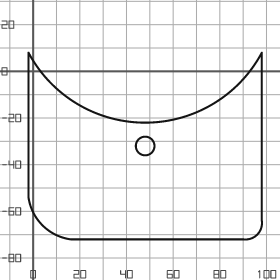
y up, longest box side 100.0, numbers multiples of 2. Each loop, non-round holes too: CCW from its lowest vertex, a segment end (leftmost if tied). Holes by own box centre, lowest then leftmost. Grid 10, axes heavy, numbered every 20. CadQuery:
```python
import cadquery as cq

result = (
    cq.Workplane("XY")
    .moveTo(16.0, -72.0)
    .lineTo(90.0, -72.0)
    .threePointArc((96.0, -70.0), (98.0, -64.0))
    .lineTo(98.0, 8.0)
    .threePointArc((48.0, -22.0), (-2.0, 8.0))
    .lineTo(-2.0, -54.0)
    .threePointArc((4.0, -66.0), (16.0, -72.0))
    .close()
    .moveTo(48.0, -32.0)
    .circle(4.0)
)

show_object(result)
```